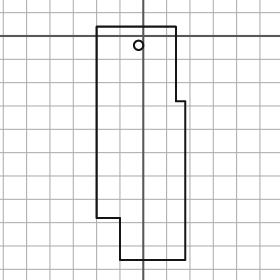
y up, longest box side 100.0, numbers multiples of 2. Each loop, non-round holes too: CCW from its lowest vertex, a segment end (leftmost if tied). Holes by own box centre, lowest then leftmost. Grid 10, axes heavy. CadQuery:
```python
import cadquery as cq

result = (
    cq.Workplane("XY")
    .moveTo(-10.0, -96.0)
    .lineTo(18.0, -96.0)
    .lineTo(18.0, -28.0)
    .lineTo(14.0, -28.0)
    .lineTo(14.0, 4.0)
    .lineTo(-20.0, 4.0)
    .lineTo(-20.0, -78.0)
    .lineTo(-10.0, -78.0)
    .close()
    .moveTo(-2.0, -4.0)
    .circle(2.0)
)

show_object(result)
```